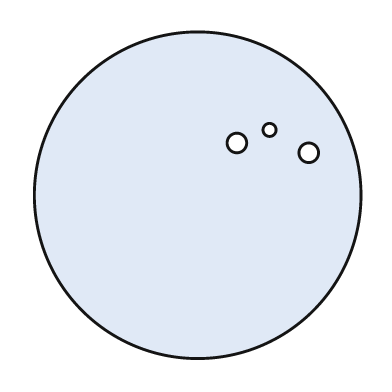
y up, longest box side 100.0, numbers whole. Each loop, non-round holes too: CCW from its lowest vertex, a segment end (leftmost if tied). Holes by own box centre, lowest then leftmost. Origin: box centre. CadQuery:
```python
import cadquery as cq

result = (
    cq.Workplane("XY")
    .moveTo(0.0, 0.0)
    .circle(50.0)
    .moveTo(34.0, 13.0)
    .circle(3.0)
    .moveTo(12.0, 16.0)
    .circle(3.0)
    .moveTo(22.0, 20.0)
    .circle(2.0)
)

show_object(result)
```